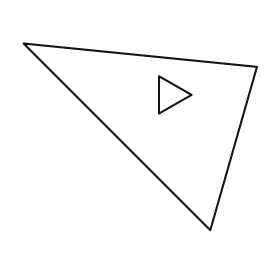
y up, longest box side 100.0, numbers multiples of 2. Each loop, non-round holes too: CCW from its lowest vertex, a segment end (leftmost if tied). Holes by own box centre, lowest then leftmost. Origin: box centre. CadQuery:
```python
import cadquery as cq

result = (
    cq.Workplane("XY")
    .moveTo(30.0, -40.0)
    .lineTo(50.0, 30.0)
    .lineTo(-50.0, 40.0)
    .close()
    .moveTo(8.0, 10.0)
    .lineTo(22.0, 18.0)
    .lineTo(8.0, 26.0)
    .close()
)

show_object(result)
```